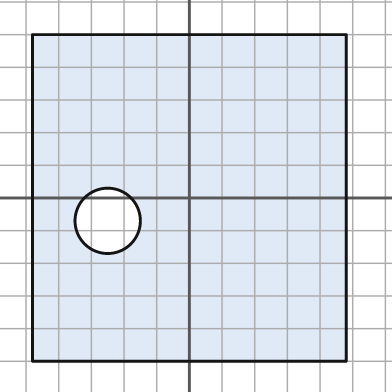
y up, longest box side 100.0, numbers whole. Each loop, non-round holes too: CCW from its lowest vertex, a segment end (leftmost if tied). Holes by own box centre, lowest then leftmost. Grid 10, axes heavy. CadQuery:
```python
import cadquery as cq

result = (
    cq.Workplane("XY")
    .moveTo(-48.0, -50.0)
    .lineTo(48.0, -50.0)
    .lineTo(48.0, 50.0)
    .lineTo(-48.0, 50.0)
    .close()
    .moveTo(-25.0, -7.0)
    .circle(10.0)
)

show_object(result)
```